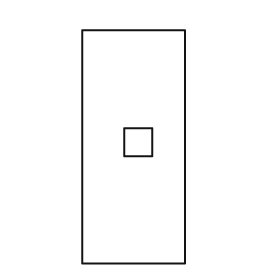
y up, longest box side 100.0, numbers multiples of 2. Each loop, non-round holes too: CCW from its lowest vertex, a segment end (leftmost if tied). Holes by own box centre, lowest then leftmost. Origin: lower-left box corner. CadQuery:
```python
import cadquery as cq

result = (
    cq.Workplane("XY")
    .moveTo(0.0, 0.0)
    .lineTo(44.0, 0.0)
    .lineTo(44.0, 100.0)
    .lineTo(0.0, 100.0)
    .close()
    .moveTo(18.0, 46.0)
    .lineTo(30.0, 46.0)
    .lineTo(30.0, 58.0)
    .lineTo(18.0, 58.0)
    .close()
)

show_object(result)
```